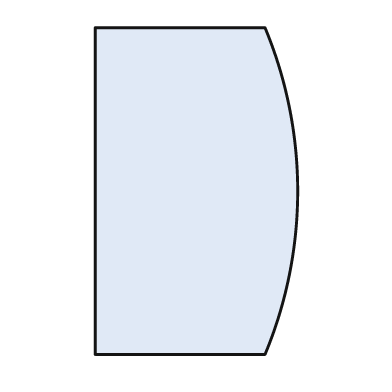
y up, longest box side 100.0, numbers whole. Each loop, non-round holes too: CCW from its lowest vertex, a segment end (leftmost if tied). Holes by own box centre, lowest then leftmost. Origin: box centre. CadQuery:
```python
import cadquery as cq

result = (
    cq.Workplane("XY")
    .moveTo(-31.0, -50.0)
    .lineTo(21.0, -50.0)
    .threePointArc((31.0, 0.0), (21.0, 50.0))
    .lineTo(-31.0, 50.0)
    .close()
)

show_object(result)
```